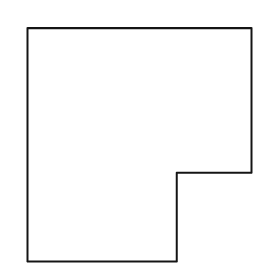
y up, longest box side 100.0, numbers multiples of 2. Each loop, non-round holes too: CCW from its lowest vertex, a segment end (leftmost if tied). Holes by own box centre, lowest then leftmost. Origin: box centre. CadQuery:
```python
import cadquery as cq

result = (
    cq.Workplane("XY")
    .moveTo(-48.0, -50.0)
    .lineTo(16.0, -50.0)
    .lineTo(16.0, -12.0)
    .lineTo(48.0, -12.0)
    .lineTo(48.0, 50.0)
    .lineTo(-48.0, 50.0)
    .close()
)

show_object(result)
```